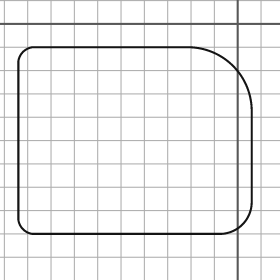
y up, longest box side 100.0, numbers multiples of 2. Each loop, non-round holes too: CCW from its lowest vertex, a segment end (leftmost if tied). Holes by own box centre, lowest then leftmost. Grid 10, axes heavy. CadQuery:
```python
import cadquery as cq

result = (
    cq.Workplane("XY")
    .moveTo(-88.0, -90.0)
    .lineTo(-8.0, -90.0)
    .threePointArc((2.0, -86.0), (6.0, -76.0))
    .lineTo(6.0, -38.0)
    .threePointArc((-2.0, -18.0), (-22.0, -10.0))
    .lineTo(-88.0, -10.0)
    .threePointArc((-92.0, -12.0), (-94.0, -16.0))
    .lineTo(-94.0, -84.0)
    .threePointArc((-92.0, -88.0), (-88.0, -90.0))
    .close()
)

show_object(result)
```